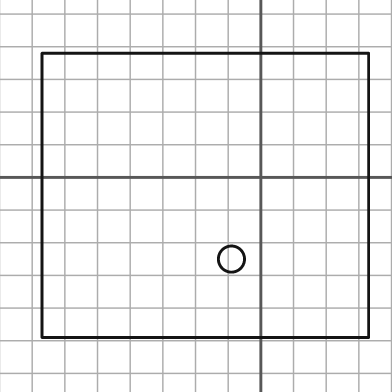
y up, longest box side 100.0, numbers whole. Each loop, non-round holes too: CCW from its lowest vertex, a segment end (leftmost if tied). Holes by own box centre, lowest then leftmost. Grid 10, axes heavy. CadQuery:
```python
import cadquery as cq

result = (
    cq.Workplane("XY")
    .moveTo(-67.0, -49.0)
    .lineTo(33.0, -49.0)
    .lineTo(33.0, 38.0)
    .lineTo(-67.0, 38.0)
    .close()
    .moveTo(-9.0, -25.0)
    .circle(4.0)
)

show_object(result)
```